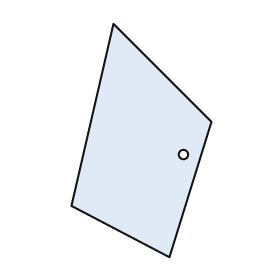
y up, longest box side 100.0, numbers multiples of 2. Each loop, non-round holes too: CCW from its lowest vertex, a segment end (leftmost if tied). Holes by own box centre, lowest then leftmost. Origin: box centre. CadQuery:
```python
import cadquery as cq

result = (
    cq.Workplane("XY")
    .moveTo(12.0, -50.0)
    .lineTo(30.0, 8.0)
    .lineTo(-12.0, 50.0)
    .lineTo(-30.0, -28.0)
    .close()
    .moveTo(18.0, -6.0)
    .circle(2.0)
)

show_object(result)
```